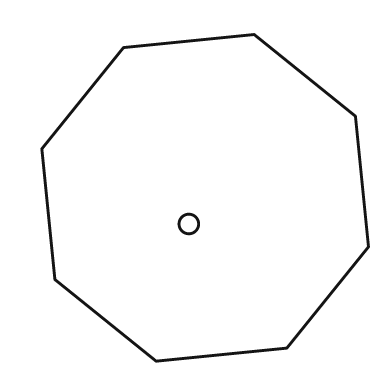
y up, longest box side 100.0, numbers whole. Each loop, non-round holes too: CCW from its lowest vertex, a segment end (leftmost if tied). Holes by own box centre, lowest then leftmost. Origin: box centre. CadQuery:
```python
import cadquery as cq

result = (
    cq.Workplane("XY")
    .moveTo(-15.0, -50.0)
    .lineTo(25.0, -46.0)
    .lineTo(50.0, -15.0)
    .lineTo(46.0, 25.0)
    .lineTo(15.0, 50.0)
    .lineTo(-25.0, 46.0)
    .lineTo(-50.0, 15.0)
    .lineTo(-46.0, -25.0)
    .close()
    .moveTo(-5.0, -8.0)
    .circle(3.0)
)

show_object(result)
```